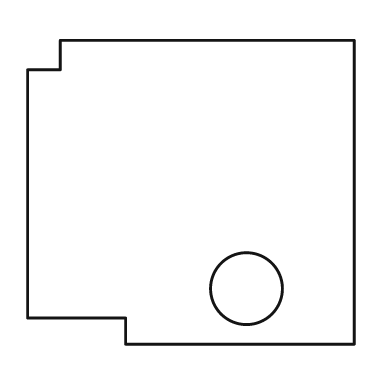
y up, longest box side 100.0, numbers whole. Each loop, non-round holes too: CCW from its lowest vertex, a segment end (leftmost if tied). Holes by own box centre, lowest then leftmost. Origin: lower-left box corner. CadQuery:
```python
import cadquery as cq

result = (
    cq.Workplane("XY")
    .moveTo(30.0, 0.0)
    .lineTo(100.0, 0.0)
    .lineTo(100.0, 93.0)
    .lineTo(10.0, 93.0)
    .lineTo(10.0, 84.0)
    .lineTo(0.0, 84.0)
    .lineTo(0.0, 8.0)
    .lineTo(30.0, 8.0)
    .close()
    .moveTo(67.0, 17.0)
    .circle(11.0)
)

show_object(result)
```